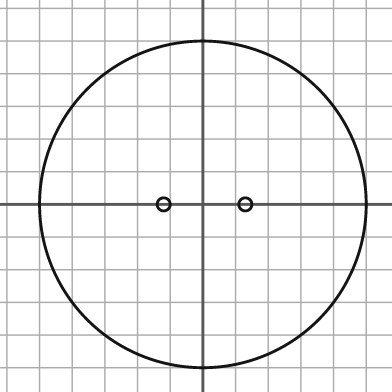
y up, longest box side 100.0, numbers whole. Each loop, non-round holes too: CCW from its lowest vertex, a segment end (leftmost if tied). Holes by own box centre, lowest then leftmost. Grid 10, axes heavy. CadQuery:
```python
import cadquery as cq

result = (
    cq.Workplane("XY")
    .moveTo(0.0, 0.0)
    .circle(50.0)
    .moveTo(-12.0, 0.0)
    .circle(2.0)
    .moveTo(13.0, 0.0)
    .circle(2.0)
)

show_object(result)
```